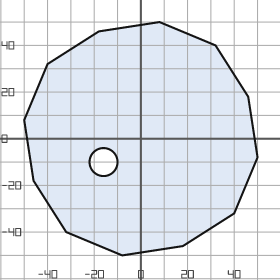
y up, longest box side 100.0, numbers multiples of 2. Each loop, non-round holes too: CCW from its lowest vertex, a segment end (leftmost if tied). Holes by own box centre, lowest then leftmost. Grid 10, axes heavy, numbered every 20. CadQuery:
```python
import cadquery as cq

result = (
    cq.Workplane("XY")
    .moveTo(-8.0, -50.0)
    .lineTo(18.0, -46.0)
    .lineTo(40.0, -32.0)
    .lineTo(50.0, -8.0)
    .lineTo(46.0, 18.0)
    .lineTo(32.0, 40.0)
    .lineTo(8.0, 50.0)
    .lineTo(-18.0, 46.0)
    .lineTo(-40.0, 32.0)
    .lineTo(-50.0, 8.0)
    .lineTo(-46.0, -18.0)
    .lineTo(-32.0, -40.0)
    .close()
    .moveTo(-16.0, -10.0)
    .circle(6.0)
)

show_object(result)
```